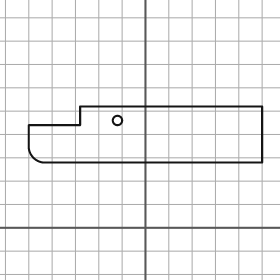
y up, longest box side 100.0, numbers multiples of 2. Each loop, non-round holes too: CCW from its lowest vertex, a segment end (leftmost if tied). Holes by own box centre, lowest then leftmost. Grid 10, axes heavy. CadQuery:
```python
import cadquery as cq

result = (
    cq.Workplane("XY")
    .moveTo(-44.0, 28.0)
    .lineTo(50.0, 28.0)
    .lineTo(50.0, 52.0)
    .lineTo(-28.0, 52.0)
    .lineTo(-28.0, 44.0)
    .lineTo(-50.0, 44.0)
    .lineTo(-50.0, 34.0)
    .threePointArc((-48.0, 30.0), (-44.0, 28.0))
    .close()
    .moveTo(-12.0, 46.0)
    .circle(2.0)
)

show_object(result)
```